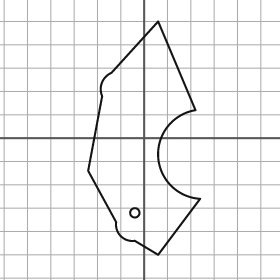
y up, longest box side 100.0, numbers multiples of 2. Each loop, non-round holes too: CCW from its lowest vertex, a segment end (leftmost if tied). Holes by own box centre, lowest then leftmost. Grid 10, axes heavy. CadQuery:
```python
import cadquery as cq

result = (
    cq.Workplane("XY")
    .moveTo(6.0, -50.0)
    .lineTo(24.0, -26.0)
    .threePointArc((6.0, -8.0), (22.0, 12.0))
    .lineTo(6.0, 50.0)
    .lineTo(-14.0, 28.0)
    .threePointArc((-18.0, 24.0), (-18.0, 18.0))
    .lineTo(-24.0, -14.0)
    .lineTo(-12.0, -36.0)
    .threePointArc((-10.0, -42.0), (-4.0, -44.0))
    .close()
    .moveTo(-4.0, -32.0)
    .circle(2.0)
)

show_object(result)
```